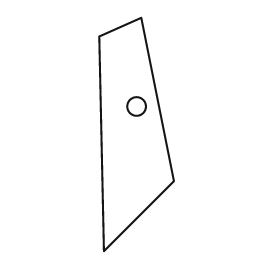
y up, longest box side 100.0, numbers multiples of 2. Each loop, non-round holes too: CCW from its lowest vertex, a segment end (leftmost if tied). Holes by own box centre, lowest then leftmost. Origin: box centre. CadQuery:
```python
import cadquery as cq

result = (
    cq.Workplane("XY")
    .moveTo(-14.0, -50.0)
    .lineTo(16.0, -20.0)
    .lineTo(2.0, 50.0)
    .lineTo(-16.0, 42.0)
    .close()
    .moveTo(0.0, 12.0)
    .circle(4.0)
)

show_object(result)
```